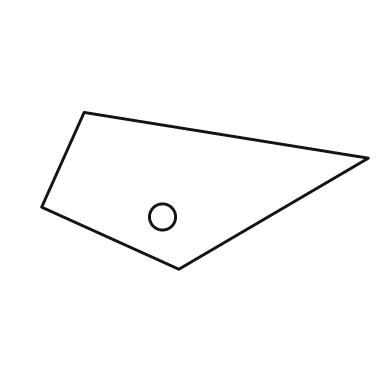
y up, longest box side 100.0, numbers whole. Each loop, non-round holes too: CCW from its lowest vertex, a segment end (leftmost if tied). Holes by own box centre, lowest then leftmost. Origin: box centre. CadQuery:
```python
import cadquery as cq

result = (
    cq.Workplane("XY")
    .moveTo(-8.0, -24.0)
    .lineTo(50.0, 10.0)
    .lineTo(-37.0, 24.0)
    .lineTo(-50.0, -5.0)
    .close()
    .moveTo(-13.0, -8.0)
    .circle(4.0)
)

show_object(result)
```